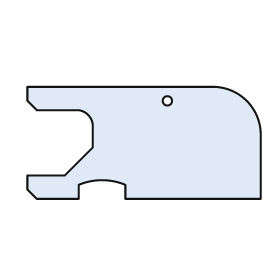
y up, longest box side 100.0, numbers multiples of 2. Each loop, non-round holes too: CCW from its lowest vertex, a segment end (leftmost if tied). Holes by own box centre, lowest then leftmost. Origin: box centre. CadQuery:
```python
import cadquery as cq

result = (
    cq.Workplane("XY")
    .moveTo(-46.0, -24.0)
    .lineTo(-28.0, -24.0)
    .lineTo(-28.0, -18.0)
    .threePointArc((-18.0, -16.0), (-8.0, -18.0))
    .lineTo(-8.0, -24.0)
    .lineTo(50.0, -24.0)
    .lineTo(50.0, 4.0)
    .threePointArc((44.0, 18.0), (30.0, 24.0))
    .lineTo(-50.0, 24.0)
    .lineTo(-50.0, 18.0)
    .lineTo(-46.0, 14.0)
    .lineTo(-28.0, 14.0)
    .threePointArc((-24.0, 12.0), (-22.0, 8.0))
    .lineTo(-22.0, -2.0)
    .lineTo(-34.0, -14.0)
    .lineTo(-50.0, -14.0)
    .lineTo(-50.0, -20.0)
    .close()
    .moveTo(10.0, 18.0)
    .circle(2.0)
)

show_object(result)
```